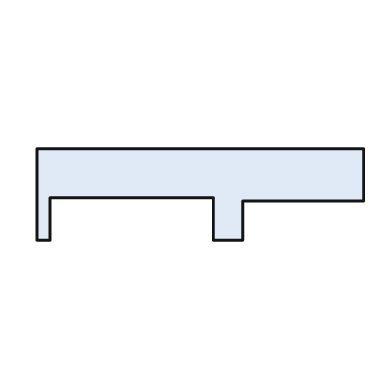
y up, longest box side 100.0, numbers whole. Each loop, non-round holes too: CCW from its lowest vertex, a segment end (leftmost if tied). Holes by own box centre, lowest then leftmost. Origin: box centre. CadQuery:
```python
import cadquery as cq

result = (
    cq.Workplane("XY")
    .moveTo(-50.0, -14.0)
    .lineTo(-46.0, -14.0)
    .lineTo(-46.0, -1.0)
    .lineTo(4.0, -1.0)
    .lineTo(4.0, -14.0)
    .lineTo(13.0, -14.0)
    .lineTo(13.0, -2.0)
    .lineTo(50.0, -2.0)
    .lineTo(50.0, 14.0)
    .lineTo(-50.0, 14.0)
    .close()
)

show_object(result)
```